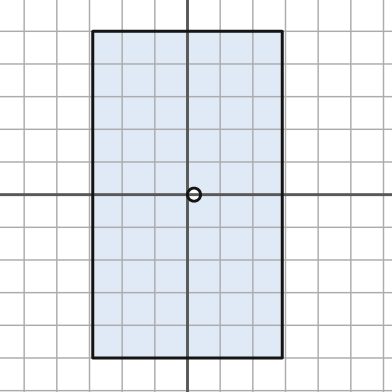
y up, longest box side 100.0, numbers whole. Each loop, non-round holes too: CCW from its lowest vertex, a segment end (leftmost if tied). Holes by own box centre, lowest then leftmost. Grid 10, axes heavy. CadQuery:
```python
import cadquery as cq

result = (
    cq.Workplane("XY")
    .moveTo(-29.0, -50.0)
    .lineTo(29.0, -50.0)
    .lineTo(29.0, 50.0)
    .lineTo(-29.0, 50.0)
    .close()
    .moveTo(2.0, 0.0)
    .circle(2.0)
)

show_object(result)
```